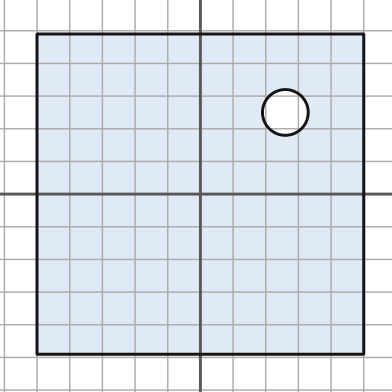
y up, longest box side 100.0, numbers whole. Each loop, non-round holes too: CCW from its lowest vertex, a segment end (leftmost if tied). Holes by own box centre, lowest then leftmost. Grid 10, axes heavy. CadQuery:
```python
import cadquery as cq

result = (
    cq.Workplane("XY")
    .moveTo(-50.0, -49.0)
    .lineTo(50.0, -49.0)
    .lineTo(50.0, 49.0)
    .lineTo(-50.0, 49.0)
    .close()
    .moveTo(26.0, 25.0)
    .circle(7.0)
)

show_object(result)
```